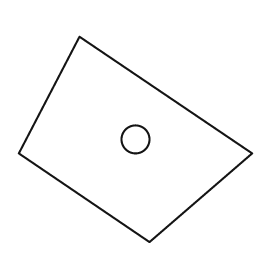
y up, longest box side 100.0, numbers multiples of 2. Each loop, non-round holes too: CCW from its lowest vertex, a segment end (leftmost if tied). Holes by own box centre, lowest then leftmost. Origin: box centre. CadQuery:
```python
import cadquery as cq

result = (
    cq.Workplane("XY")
    .moveTo(6.0, -44.0)
    .lineTo(50.0, -6.0)
    .lineTo(-24.0, 44.0)
    .lineTo(-50.0, -6.0)
    .close()
    .moveTo(0.0, 0.0)
    .circle(6.0)
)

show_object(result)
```